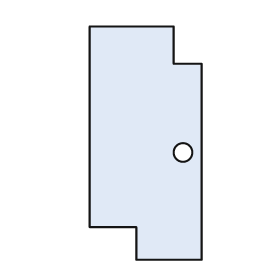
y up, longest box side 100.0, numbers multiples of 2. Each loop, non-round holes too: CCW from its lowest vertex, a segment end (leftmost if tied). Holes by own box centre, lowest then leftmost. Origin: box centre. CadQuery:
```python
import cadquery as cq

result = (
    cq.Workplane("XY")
    .moveTo(-4.0, -50.0)
    .lineTo(24.0, -50.0)
    .lineTo(24.0, 34.0)
    .lineTo(12.0, 34.0)
    .lineTo(12.0, 50.0)
    .lineTo(-24.0, 50.0)
    .lineTo(-24.0, -36.0)
    .lineTo(-4.0, -36.0)
    .close()
    .moveTo(16.0, -4.0)
    .circle(4.0)
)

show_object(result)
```